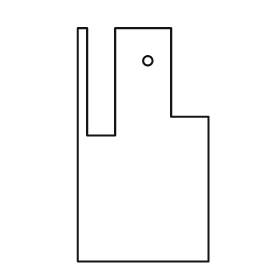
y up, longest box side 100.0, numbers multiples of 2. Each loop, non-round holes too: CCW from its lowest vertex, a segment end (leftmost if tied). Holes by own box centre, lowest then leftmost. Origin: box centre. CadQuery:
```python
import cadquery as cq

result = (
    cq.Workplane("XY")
    .moveTo(-28.0, -50.0)
    .lineTo(28.0, -50.0)
    .lineTo(28.0, 12.0)
    .lineTo(12.0, 12.0)
    .lineTo(12.0, 50.0)
    .lineTo(-12.0, 50.0)
    .lineTo(-12.0, 4.0)
    .lineTo(-24.0, 4.0)
    .lineTo(-24.0, 50.0)
    .lineTo(-28.0, 50.0)
    .close()
    .moveTo(2.0, 36.0)
    .circle(2.0)
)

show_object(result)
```